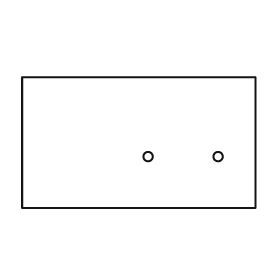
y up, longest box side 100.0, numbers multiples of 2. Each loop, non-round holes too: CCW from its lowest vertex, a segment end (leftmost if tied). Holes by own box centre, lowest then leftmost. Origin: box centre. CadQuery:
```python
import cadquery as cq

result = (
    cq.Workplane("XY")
    .moveTo(-50.0, -28.0)
    .lineTo(50.0, -28.0)
    .lineTo(50.0, 28.0)
    .lineTo(-50.0, 28.0)
    .close()
    .moveTo(4.0, -6.0)
    .circle(2.0)
    .moveTo(34.0, -6.0)
    .circle(2.0)
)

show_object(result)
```